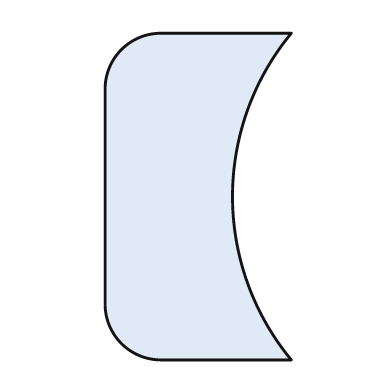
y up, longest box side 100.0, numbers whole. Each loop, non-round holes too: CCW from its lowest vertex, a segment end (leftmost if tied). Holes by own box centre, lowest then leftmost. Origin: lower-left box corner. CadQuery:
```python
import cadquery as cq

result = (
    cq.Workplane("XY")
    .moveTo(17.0, 0.0)
    .lineTo(57.0, 0.0)
    .threePointArc((39.0, 50.0), (57.0, 100.0))
    .lineTo(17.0, 100.0)
    .threePointArc((5.0, 95.0), (0.0, 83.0))
    .lineTo(0.0, 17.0)
    .threePointArc((5.0, 5.0), (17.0, 0.0))
    .close()
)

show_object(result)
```